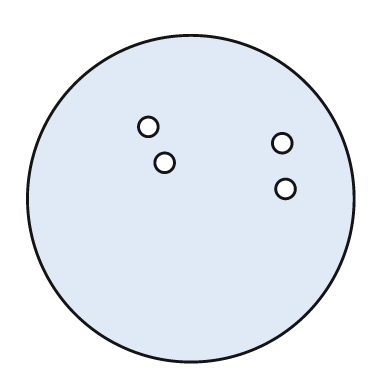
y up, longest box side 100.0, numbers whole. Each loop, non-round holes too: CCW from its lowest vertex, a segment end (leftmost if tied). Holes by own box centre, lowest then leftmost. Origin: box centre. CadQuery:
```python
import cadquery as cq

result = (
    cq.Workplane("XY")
    .moveTo(0.0, 0.0)
    .circle(50.0)
    .moveTo(29.0, 3.0)
    .circle(3.0)
    .moveTo(-8.0, 11.0)
    .circle(3.0)
    .moveTo(28.0, 17.0)
    .circle(3.0)
    .moveTo(-13.0, 22.0)
    .circle(3.0)
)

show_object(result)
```